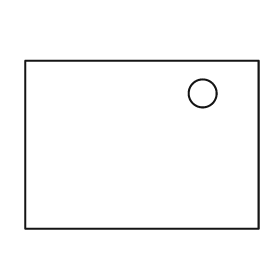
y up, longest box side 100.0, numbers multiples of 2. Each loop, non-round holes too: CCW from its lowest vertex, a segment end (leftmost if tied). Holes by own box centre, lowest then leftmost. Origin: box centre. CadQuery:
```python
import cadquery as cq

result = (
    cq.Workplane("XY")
    .moveTo(-50.0, -36.0)
    .lineTo(50.0, -36.0)
    .lineTo(50.0, 36.0)
    .lineTo(-50.0, 36.0)
    .close()
    .moveTo(26.0, 22.0)
    .circle(6.0)
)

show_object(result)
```